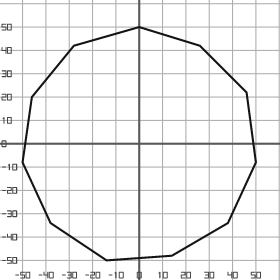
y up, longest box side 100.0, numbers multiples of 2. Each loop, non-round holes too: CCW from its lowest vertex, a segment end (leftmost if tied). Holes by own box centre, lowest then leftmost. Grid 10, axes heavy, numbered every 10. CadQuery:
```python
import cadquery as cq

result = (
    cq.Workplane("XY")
    .moveTo(-14.0, -50.0)
    .lineTo(14.0, -48.0)
    .lineTo(38.0, -34.0)
    .lineTo(50.0, -8.0)
    .lineTo(46.0, 22.0)
    .lineTo(26.0, 42.0)
    .lineTo(0.0, 50.0)
    .lineTo(-28.0, 42.0)
    .lineTo(-46.0, 20.0)
    .lineTo(-50.0, -8.0)
    .lineTo(-38.0, -34.0)
    .close()
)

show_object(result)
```